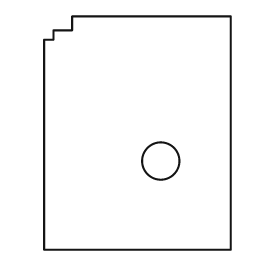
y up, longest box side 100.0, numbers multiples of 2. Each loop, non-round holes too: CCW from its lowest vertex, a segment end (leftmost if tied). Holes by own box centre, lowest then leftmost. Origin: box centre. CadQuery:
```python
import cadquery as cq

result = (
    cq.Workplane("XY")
    .moveTo(-40.0, -50.0)
    .lineTo(40.0, -50.0)
    .lineTo(40.0, 50.0)
    .lineTo(-28.0, 50.0)
    .lineTo(-28.0, 44.0)
    .lineTo(-36.0, 44.0)
    .lineTo(-36.0, 40.0)
    .lineTo(-40.0, 40.0)
    .close()
    .moveTo(10.0, -12.0)
    .circle(8.0)
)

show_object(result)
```